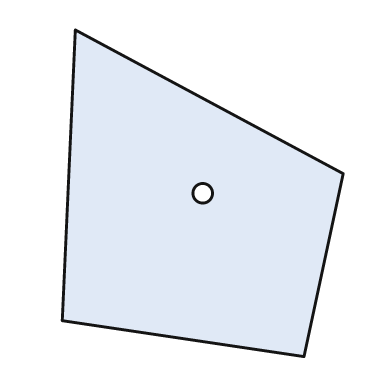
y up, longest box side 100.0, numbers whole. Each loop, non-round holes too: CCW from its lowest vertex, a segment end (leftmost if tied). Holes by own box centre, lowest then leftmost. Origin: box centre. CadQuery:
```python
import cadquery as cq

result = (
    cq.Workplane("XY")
    .moveTo(31.0, -50.0)
    .lineTo(43.0, 6.0)
    .lineTo(-39.0, 50.0)
    .lineTo(-43.0, -39.0)
    .close()
    .moveTo(0.0, 0.0)
    .circle(3.0)
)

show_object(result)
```